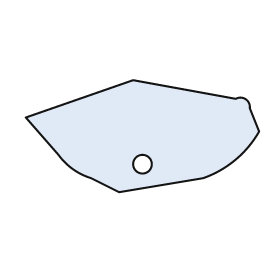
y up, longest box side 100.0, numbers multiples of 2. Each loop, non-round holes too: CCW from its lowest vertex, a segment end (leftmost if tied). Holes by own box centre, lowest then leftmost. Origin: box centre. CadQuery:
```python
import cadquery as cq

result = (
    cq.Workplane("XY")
    .moveTo(-10.0, -24.0)
    .lineTo(26.0, -18.0)
    .threePointArc((40.0, -10.0), (50.0, 2.0))
    .lineTo(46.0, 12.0)
    .threePointArc((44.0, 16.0), (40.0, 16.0))
    .lineTo(-4.0, 24.0)
    .lineTo(-50.0, 8.0)
    .lineTo(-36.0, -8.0)
    .threePointArc((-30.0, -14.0), (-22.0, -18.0))
    .close()
    .moveTo(0.0, -12.0)
    .circle(4.0)
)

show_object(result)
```